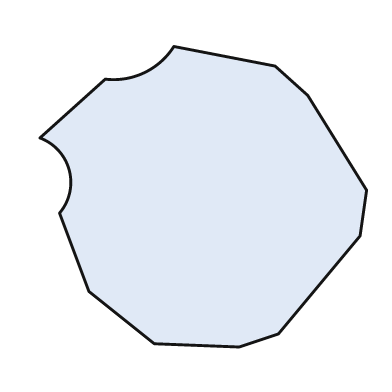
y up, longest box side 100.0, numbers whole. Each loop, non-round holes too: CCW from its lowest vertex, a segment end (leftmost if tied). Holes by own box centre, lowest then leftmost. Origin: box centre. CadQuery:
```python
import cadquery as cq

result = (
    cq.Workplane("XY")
    .moveTo(11.0, -46.0)
    .lineTo(23.0, -42.0)
    .lineTo(48.0, -12.0)
    .lineTo(50.0, 2.0)
    .lineTo(32.0, 31.0)
    .lineTo(22.0, 40.0)
    .lineTo(-9.0, 46.0)
    .threePointArc((-18.0, 38.0), (-30.0, 36.0))
    .lineTo(-50.0, 18.0)
    .threePointArc((-41.0, 8.0), (-44.0, -5.0))
    .lineTo(-35.0, -29.0)
    .lineTo(-15.0, -45.0)
    .close()
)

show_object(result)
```